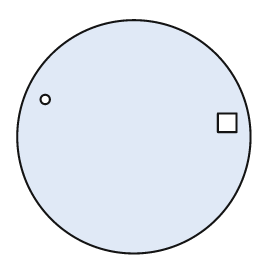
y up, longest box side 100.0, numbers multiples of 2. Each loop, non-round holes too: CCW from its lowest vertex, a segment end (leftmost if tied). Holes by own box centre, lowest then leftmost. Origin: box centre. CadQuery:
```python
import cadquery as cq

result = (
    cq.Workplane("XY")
    .moveTo(0.0, 0.0)
    .circle(50.0)
    .moveTo(36.0, 2.0)
    .lineTo(44.0, 2.0)
    .lineTo(44.0, 10.0)
    .lineTo(36.0, 10.0)
    .close()
    .moveTo(-38.0, 16.0)
    .circle(2.0)
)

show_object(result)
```